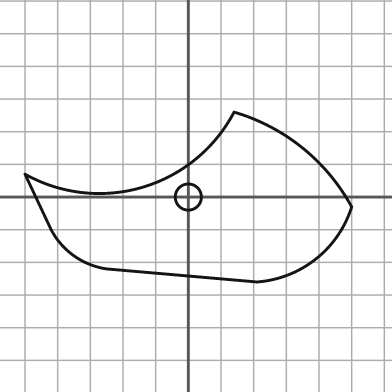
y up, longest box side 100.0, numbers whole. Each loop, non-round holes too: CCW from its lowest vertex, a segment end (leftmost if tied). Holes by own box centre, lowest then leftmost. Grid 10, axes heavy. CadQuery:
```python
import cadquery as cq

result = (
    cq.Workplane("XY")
    .moveTo(21.0, -26.0)
    .threePointArc((39.0, -19.0), (50.0, -3.0))
    .threePointArc((35.0, 15.0), (14.0, 26.0))
    .threePointArc((-14.0, 3.0), (-50.0, 7.0))
    .lineTo(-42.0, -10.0)
    .threePointArc((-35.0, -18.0), (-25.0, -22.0))
    .close()
    .moveTo(0.0, 0.0)
    .circle(4.0)
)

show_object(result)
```